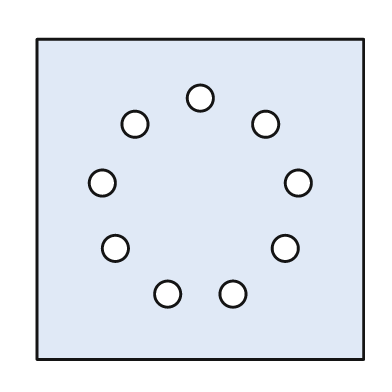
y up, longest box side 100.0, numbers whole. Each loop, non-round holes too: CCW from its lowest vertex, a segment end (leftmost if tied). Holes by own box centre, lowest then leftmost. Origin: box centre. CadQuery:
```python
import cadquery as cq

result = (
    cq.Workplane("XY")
    .moveTo(-50.0, -49.0)
    .lineTo(50.0, -49.0)
    .lineTo(50.0, 49.0)
    .lineTo(-50.0, 49.0)
    .close()
    .moveTo(-10.0, -29.0)
    .circle(4.0)
    .moveTo(10.0, -29.0)
    .circle(4.0)
    .moveTo(-26.0, -15.0)
    .circle(4.0)
    .moveTo(26.0, -15.0)
    .circle(4.0)
    .moveTo(-30.0, 5.0)
    .circle(4.0)
    .moveTo(30.0, 5.0)
    .circle(4.0)
    .moveTo(-20.0, 23.0)
    .circle(4.0)
    .moveTo(20.0, 23.0)
    .circle(4.0)
    .moveTo(0.0, 31.0)
    .circle(4.0)
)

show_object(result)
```